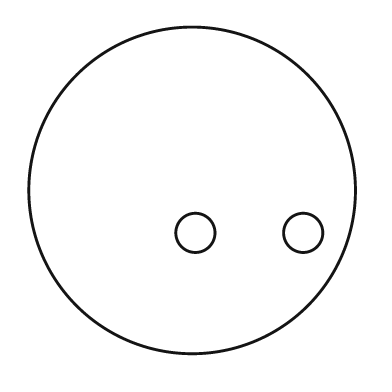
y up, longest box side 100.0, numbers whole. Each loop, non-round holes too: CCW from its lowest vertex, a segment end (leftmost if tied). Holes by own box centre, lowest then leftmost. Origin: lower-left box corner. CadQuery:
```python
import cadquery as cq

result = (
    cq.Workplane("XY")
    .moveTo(50.0, 50.0)
    .circle(50.0)
    .moveTo(51.0, 37.0)
    .circle(6.0)
    .moveTo(84.0, 37.0)
    .circle(6.0)
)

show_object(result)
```